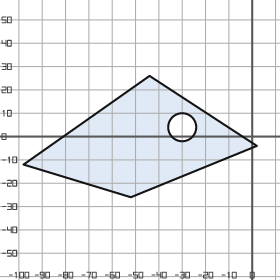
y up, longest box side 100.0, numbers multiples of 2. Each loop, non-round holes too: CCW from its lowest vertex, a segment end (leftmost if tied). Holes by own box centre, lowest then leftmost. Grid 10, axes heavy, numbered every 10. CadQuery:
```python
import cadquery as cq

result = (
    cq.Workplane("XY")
    .moveTo(-52.0, -26.0)
    .lineTo(2.0, -4.0)
    .lineTo(-44.0, 26.0)
    .lineTo(-98.0, -12.0)
    .close()
    .moveTo(-30.0, 4.0)
    .circle(6.0)
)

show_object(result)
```